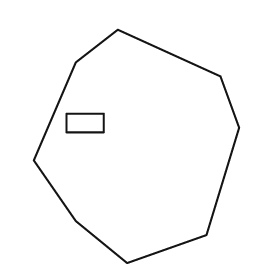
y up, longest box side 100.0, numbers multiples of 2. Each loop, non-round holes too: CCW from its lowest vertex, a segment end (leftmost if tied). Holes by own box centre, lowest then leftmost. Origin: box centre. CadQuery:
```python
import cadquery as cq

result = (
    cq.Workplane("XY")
    .moveTo(-4.0, -50.0)
    .lineTo(30.0, -38.0)
    .lineTo(44.0, 8.0)
    .lineTo(36.0, 30.0)
    .lineTo(-8.0, 50.0)
    .lineTo(-26.0, 36.0)
    .lineTo(-44.0, -6.0)
    .lineTo(-26.0, -32.0)
    .close()
    .moveTo(-30.0, 6.0)
    .lineTo(-14.0, 6.0)
    .lineTo(-14.0, 14.0)
    .lineTo(-30.0, 14.0)
    .close()
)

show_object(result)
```